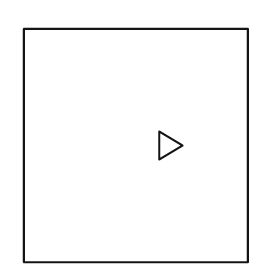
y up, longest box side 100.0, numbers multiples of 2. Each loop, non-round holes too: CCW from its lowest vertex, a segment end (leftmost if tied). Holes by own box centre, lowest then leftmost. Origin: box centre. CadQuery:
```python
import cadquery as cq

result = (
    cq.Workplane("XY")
    .moveTo(-48.0, -50.0)
    .lineTo(48.0, -50.0)
    .lineTo(48.0, 50.0)
    .lineTo(-48.0, 50.0)
    .close()
    .moveTo(10.0, -6.0)
    .lineTo(20.0, 0.0)
    .lineTo(10.0, 6.0)
    .close()
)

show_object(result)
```